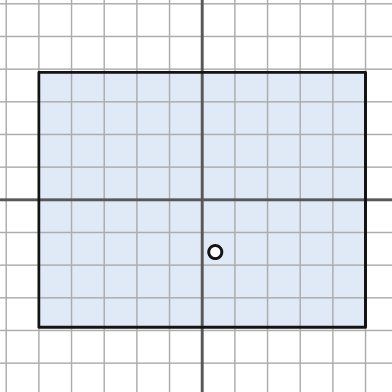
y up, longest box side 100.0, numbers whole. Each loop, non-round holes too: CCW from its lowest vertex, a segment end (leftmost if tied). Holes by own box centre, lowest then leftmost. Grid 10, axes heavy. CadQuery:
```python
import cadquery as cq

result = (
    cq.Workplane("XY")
    .moveTo(-50.0, -39.0)
    .lineTo(50.0, -39.0)
    .lineTo(50.0, 39.0)
    .lineTo(-50.0, 39.0)
    .close()
    .moveTo(4.0, -16.0)
    .circle(2.0)
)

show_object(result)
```